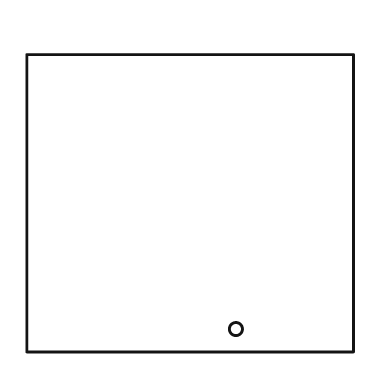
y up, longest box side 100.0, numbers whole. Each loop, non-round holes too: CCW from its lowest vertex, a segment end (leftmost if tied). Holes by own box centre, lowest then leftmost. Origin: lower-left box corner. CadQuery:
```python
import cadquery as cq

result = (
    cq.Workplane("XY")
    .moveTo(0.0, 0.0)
    .lineTo(100.0, 0.0)
    .lineTo(100.0, 91.0)
    .lineTo(0.0, 91.0)
    .close()
    .moveTo(64.0, 7.0)
    .circle(2.0)
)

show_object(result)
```